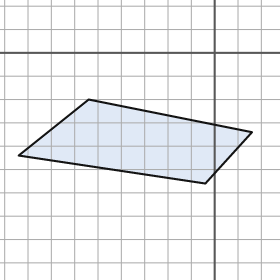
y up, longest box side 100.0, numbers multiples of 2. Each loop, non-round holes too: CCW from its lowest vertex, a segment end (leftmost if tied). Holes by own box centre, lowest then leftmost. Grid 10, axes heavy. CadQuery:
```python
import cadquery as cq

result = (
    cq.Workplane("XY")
    .moveTo(-4.0, -56.0)
    .lineTo(16.0, -34.0)
    .lineTo(-54.0, -20.0)
    .lineTo(-84.0, -44.0)
    .close()
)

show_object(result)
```